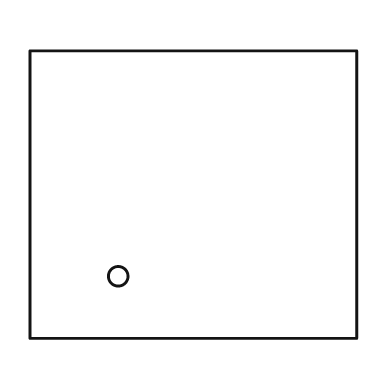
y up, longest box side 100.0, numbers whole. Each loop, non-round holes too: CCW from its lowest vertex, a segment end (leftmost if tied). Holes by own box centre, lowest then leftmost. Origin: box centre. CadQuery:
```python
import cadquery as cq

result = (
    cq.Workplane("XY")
    .moveTo(-50.0, -44.0)
    .lineTo(50.0, -44.0)
    .lineTo(50.0, 44.0)
    .lineTo(-50.0, 44.0)
    .close()
    .moveTo(-23.0, -25.0)
    .circle(3.0)
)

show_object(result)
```